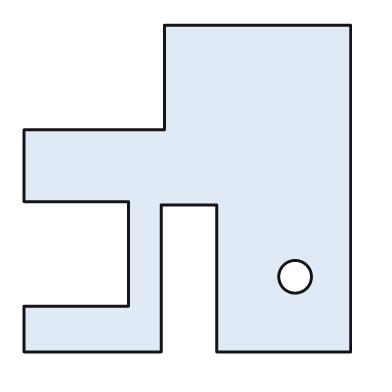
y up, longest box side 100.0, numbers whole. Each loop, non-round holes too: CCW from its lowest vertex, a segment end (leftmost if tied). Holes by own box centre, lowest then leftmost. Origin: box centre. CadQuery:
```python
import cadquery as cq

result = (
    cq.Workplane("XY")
    .moveTo(-50.0, -50.0)
    .lineTo(-8.0, -50.0)
    .lineTo(-8.0, -5.0)
    .lineTo(9.0, -5.0)
    .lineTo(9.0, -50.0)
    .lineTo(50.0, -50.0)
    .lineTo(50.0, 50.0)
    .lineTo(-7.0, 50.0)
    .lineTo(-7.0, 18.0)
    .lineTo(-50.0, 18.0)
    .lineTo(-50.0, -4.0)
    .lineTo(-18.0, -4.0)
    .lineTo(-18.0, -36.0)
    .lineTo(-50.0, -36.0)
    .close()
    .moveTo(33.0, -27.0)
    .circle(5.0)
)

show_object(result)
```